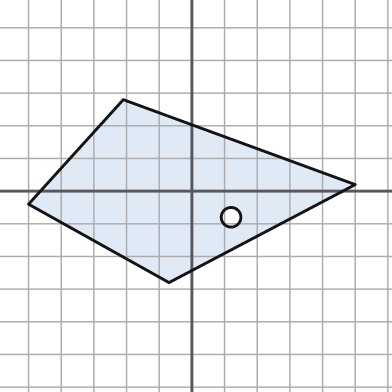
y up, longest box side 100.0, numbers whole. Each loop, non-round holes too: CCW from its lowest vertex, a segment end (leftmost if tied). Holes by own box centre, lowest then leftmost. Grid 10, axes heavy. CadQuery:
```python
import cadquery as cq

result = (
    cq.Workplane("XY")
    .moveTo(-7.0, -28.0)
    .lineTo(50.0, 2.0)
    .lineTo(-21.0, 28.0)
    .lineTo(-50.0, -4.0)
    .close()
    .moveTo(12.0, -8.0)
    .circle(3.0)
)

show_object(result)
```